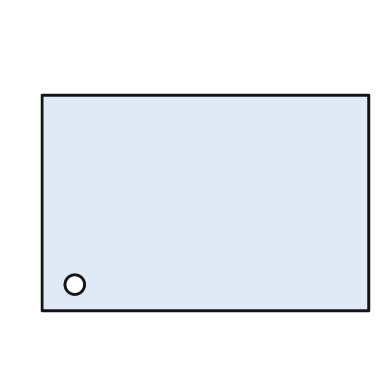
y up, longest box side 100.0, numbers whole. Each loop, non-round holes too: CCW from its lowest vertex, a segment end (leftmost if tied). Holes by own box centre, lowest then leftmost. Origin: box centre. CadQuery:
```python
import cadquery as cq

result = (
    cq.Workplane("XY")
    .moveTo(-50.0, -33.0)
    .lineTo(50.0, -33.0)
    .lineTo(50.0, 33.0)
    .lineTo(-50.0, 33.0)
    .close()
    .moveTo(-40.0, -25.0)
    .circle(3.0)
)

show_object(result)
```